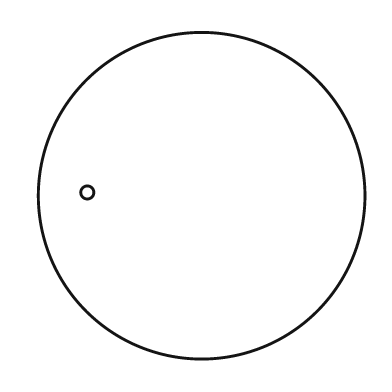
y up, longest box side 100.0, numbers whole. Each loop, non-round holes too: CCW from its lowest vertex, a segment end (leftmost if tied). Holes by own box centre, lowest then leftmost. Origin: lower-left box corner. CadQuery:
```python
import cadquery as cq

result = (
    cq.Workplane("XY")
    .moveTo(50.0, 50.0)
    .circle(50.0)
    .moveTo(15.0, 51.0)
    .circle(2.0)
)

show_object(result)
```